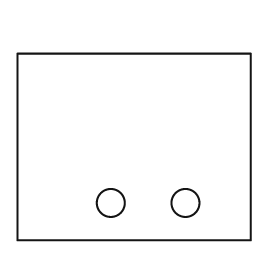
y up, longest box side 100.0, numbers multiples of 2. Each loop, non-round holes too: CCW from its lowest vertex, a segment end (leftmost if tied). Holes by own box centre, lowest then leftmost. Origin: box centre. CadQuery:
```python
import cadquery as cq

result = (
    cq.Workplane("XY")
    .moveTo(-50.0, -40.0)
    .lineTo(50.0, -40.0)
    .lineTo(50.0, 40.0)
    .lineTo(-50.0, 40.0)
    .close()
    .moveTo(-10.0, -24.0)
    .circle(6.0)
    .moveTo(22.0, -24.0)
    .circle(6.0)
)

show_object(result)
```